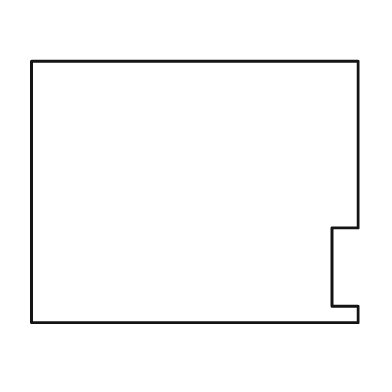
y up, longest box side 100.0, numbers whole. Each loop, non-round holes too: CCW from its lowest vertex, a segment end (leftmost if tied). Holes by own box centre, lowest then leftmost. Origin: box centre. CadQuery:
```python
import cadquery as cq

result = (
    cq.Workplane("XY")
    .moveTo(-50.0, -40.0)
    .lineTo(50.0, -40.0)
    .lineTo(50.0, -35.0)
    .lineTo(42.0, -35.0)
    .lineTo(42.0, -11.0)
    .lineTo(50.0, -11.0)
    .lineTo(50.0, 40.0)
    .lineTo(-50.0, 40.0)
    .close()
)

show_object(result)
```